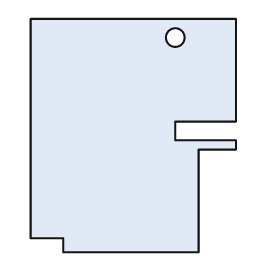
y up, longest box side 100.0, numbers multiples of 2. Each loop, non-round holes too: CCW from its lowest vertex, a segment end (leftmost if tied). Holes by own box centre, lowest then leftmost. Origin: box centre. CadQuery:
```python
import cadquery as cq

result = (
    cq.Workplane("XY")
    .moveTo(-30.0, -50.0)
    .lineTo(28.0, -50.0)
    .lineTo(28.0, -6.0)
    .lineTo(44.0, -6.0)
    .lineTo(44.0, -2.0)
    .lineTo(18.0, -2.0)
    .lineTo(18.0, 6.0)
    .lineTo(44.0, 6.0)
    .lineTo(44.0, 50.0)
    .lineTo(-44.0, 50.0)
    .lineTo(-44.0, -44.0)
    .lineTo(-30.0, -44.0)
    .close()
    .moveTo(18.0, 42.0)
    .circle(4.0)
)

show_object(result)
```